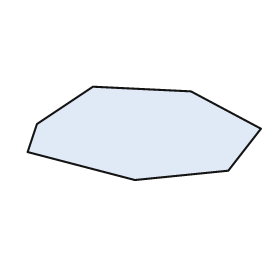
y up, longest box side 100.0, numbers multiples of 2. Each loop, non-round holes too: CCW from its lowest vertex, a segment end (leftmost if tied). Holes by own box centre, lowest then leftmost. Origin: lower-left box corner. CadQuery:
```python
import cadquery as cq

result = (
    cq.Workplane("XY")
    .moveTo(46.0, 0.0)
    .lineTo(86.0, 4.0)
    .lineTo(100.0, 22.0)
    .lineTo(70.0, 38.0)
    .lineTo(28.0, 40.0)
    .lineTo(4.0, 24.0)
    .lineTo(0.0, 12.0)
    .close()
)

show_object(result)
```